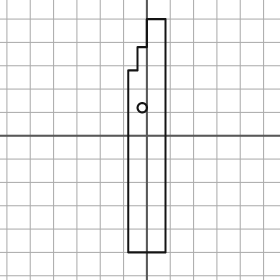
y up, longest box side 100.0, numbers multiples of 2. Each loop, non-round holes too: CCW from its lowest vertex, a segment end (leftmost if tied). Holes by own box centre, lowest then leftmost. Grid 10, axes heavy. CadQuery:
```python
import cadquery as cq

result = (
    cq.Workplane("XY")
    .moveTo(-8.0, -50.0)
    .lineTo(8.0, -50.0)
    .lineTo(8.0, 50.0)
    .lineTo(0.0, 50.0)
    .lineTo(0.0, 38.0)
    .lineTo(-4.0, 38.0)
    .lineTo(-4.0, 28.0)
    .lineTo(-8.0, 28.0)
    .close()
    .moveTo(-2.0, 12.0)
    .circle(2.0)
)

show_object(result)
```